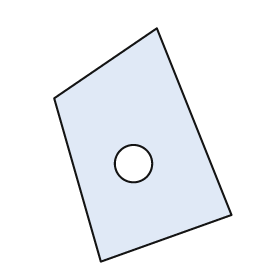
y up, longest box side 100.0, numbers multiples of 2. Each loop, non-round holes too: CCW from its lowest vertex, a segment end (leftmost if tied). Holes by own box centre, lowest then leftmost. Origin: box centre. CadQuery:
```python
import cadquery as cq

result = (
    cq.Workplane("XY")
    .moveTo(-18.0, -50.0)
    .lineTo(38.0, -30.0)
    .lineTo(6.0, 50.0)
    .lineTo(-38.0, 20.0)
    .close()
    .moveTo(-4.0, -8.0)
    .circle(8.0)
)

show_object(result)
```